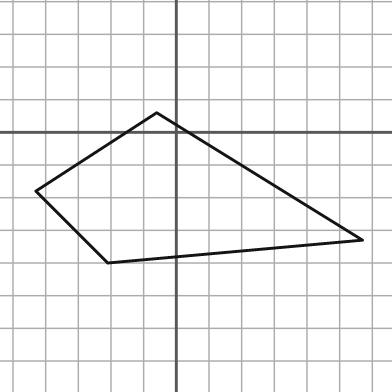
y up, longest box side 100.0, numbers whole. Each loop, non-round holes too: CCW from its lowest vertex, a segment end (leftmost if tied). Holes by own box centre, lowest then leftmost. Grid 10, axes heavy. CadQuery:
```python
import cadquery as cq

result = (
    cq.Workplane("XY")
    .moveTo(-21.0, -40.0)
    .lineTo(57.0, -33.0)
    .lineTo(-6.0, 6.0)
    .lineTo(-43.0, -18.0)
    .close()
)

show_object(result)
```